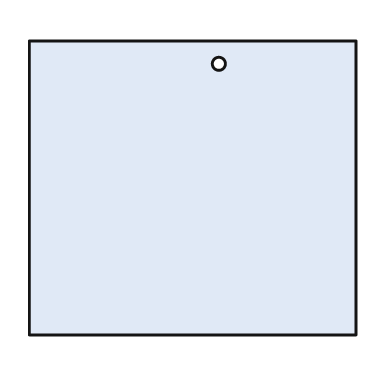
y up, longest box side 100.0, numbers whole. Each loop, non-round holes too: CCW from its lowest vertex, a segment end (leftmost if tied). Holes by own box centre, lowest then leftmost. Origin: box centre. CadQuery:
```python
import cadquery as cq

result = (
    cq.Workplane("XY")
    .moveTo(-50.0, -45.0)
    .lineTo(50.0, -45.0)
    .lineTo(50.0, 45.0)
    .lineTo(-50.0, 45.0)
    .close()
    .moveTo(8.0, 38.0)
    .circle(2.0)
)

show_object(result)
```